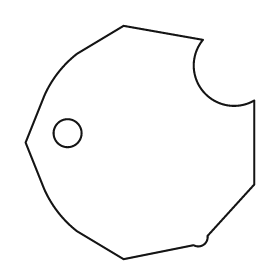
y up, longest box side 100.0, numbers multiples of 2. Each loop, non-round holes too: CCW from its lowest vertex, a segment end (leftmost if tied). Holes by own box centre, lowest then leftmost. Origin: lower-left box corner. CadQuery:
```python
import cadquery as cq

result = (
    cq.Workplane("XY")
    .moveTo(42.0, 0.0)
    .lineTo(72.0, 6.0)
    .threePointArc((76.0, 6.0), (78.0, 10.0))
    .lineTo(98.0, 32.0)
    .lineTo(98.0, 68.0)
    .threePointArc((76.0, 72.0), (76.0, 94.0))
    .lineTo(42.0, 100.0)
    .lineTo(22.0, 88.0)
    .threePointArc((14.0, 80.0), (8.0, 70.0))
    .lineTo(0.0, 50.0)
    .lineTo(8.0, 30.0)
    .threePointArc((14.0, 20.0), (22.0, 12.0))
    .close()
    .moveTo(18.0, 54.0)
    .circle(6.0)
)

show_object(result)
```